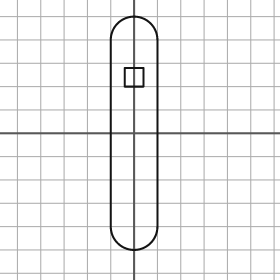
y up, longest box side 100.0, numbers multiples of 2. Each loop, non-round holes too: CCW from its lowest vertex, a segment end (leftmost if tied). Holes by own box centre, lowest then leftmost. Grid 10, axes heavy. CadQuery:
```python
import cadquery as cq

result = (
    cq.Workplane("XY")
    .moveTo(-10.0, -40.0)
    .threePointArc((0.0, -50.0), (10.0, -40.0))
    .lineTo(10.0, 40.0)
    .threePointArc((0.0, 50.0), (-10.0, 40.0))
    .close()
    .moveTo(-4.0, 20.0)
    .lineTo(4.0, 20.0)
    .lineTo(4.0, 28.0)
    .lineTo(-4.0, 28.0)
    .close()
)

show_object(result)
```